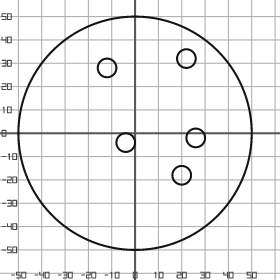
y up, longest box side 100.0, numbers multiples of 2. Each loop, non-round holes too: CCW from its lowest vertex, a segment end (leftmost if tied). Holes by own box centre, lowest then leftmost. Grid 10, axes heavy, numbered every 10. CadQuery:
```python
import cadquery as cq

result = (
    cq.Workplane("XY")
    .moveTo(0.0, 0.0)
    .circle(50.0)
    .moveTo(20.0, -18.0)
    .circle(4.0)
    .moveTo(-4.0, -4.0)
    .circle(4.0)
    .moveTo(26.0, -2.0)
    .circle(4.0)
    .moveTo(-12.0, 28.0)
    .circle(4.0)
    .moveTo(22.0, 32.0)
    .circle(4.0)
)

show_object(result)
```